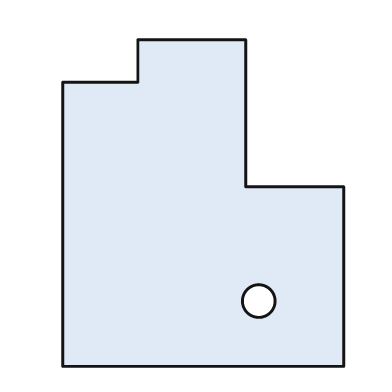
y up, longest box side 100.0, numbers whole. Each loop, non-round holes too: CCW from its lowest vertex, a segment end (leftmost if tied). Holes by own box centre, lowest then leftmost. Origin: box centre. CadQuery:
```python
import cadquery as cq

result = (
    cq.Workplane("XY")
    .moveTo(-43.0, -50.0)
    .lineTo(43.0, -50.0)
    .lineTo(43.0, 5.0)
    .lineTo(13.0, 5.0)
    .lineTo(13.0, 50.0)
    .lineTo(-20.0, 50.0)
    .lineTo(-20.0, 37.0)
    .lineTo(-43.0, 37.0)
    .close()
    .moveTo(17.0, -30.0)
    .circle(5.0)
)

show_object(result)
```